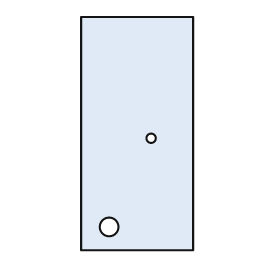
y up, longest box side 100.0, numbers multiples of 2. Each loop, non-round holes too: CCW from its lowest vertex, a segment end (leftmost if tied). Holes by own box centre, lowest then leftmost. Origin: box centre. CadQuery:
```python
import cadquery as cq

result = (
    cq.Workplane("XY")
    .moveTo(-24.0, -50.0)
    .lineTo(24.0, -50.0)
    .lineTo(24.0, 50.0)
    .lineTo(-24.0, 50.0)
    .close()
    .moveTo(-12.0, -40.0)
    .circle(4.0)
    .moveTo(6.0, -2.0)
    .circle(2.0)
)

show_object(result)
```